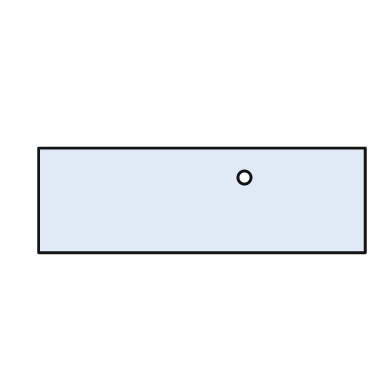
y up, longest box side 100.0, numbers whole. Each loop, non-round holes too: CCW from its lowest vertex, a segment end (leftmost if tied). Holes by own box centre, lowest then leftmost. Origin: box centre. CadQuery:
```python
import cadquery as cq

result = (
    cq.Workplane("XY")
    .moveTo(-50.0, -16.0)
    .lineTo(50.0, -16.0)
    .lineTo(50.0, 16.0)
    .lineTo(-50.0, 16.0)
    .close()
    .moveTo(13.0, 7.0)
    .circle(2.0)
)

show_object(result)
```